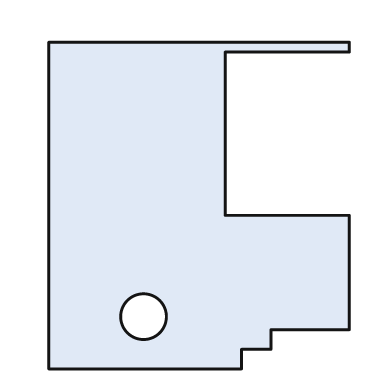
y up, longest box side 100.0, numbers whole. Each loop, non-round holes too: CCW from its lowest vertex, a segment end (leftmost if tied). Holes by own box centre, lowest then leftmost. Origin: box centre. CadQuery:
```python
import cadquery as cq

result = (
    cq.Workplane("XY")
    .moveTo(-46.0, -50.0)
    .lineTo(13.0, -50.0)
    .lineTo(13.0, -44.0)
    .lineTo(22.0, -44.0)
    .lineTo(22.0, -38.0)
    .lineTo(46.0, -38.0)
    .lineTo(46.0, -3.0)
    .lineTo(8.0, -3.0)
    .lineTo(8.0, 47.0)
    .lineTo(46.0, 47.0)
    .lineTo(46.0, 50.0)
    .lineTo(-46.0, 50.0)
    .close()
    .moveTo(-17.0, -34.0)
    .circle(7.0)
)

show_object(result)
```